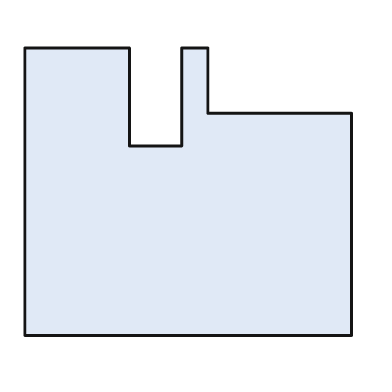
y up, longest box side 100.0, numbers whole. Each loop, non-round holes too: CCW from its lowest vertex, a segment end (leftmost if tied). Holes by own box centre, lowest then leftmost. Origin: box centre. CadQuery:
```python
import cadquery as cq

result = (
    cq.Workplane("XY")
    .moveTo(-50.0, -44.0)
    .lineTo(50.0, -44.0)
    .lineTo(50.0, 24.0)
    .lineTo(6.0, 24.0)
    .lineTo(6.0, 44.0)
    .lineTo(-2.0, 44.0)
    .lineTo(-2.0, 14.0)
    .lineTo(-18.0, 14.0)
    .lineTo(-18.0, 44.0)
    .lineTo(-50.0, 44.0)
    .close()
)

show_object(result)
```